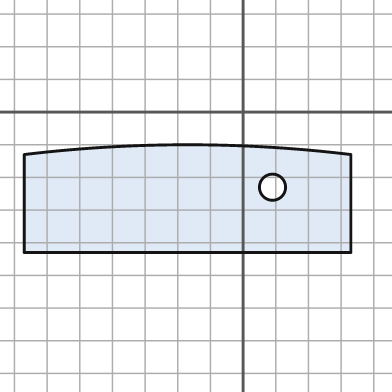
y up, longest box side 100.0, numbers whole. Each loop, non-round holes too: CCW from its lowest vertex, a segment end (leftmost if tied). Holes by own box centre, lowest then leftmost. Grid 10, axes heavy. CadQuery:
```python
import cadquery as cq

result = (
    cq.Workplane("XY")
    .moveTo(-67.0, -43.0)
    .lineTo(33.0, -43.0)
    .lineTo(33.0, -13.0)
    .threePointArc((-17.0, -10.0), (-67.0, -13.0))
    .close()
    .moveTo(9.0, -23.0)
    .circle(4.0)
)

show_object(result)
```